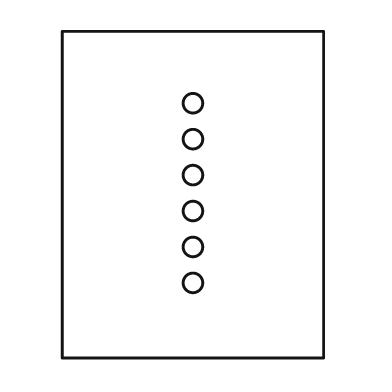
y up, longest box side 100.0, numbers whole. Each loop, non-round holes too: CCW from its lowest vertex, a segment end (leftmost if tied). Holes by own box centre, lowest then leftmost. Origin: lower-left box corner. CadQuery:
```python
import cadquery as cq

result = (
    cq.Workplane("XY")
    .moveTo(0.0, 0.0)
    .lineTo(80.0, 0.0)
    .lineTo(80.0, 100.0)
    .lineTo(0.0, 100.0)
    .close()
    .moveTo(40.0, 23.0)
    .circle(3.0)
    .moveTo(40.0, 34.0)
    .circle(3.0)
    .moveTo(40.0, 45.0)
    .circle(3.0)
    .moveTo(40.0, 56.0)
    .circle(3.0)
    .moveTo(40.0, 67.0)
    .circle(3.0)
    .moveTo(40.0, 78.0)
    .circle(3.0)
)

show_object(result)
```